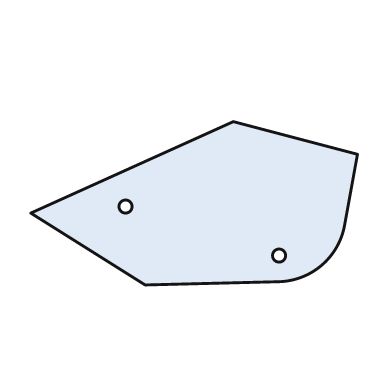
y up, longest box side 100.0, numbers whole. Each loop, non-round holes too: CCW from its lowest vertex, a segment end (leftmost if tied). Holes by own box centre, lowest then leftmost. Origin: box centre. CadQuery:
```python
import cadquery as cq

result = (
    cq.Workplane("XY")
    .moveTo(-15.0, -25.0)
    .lineTo(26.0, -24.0)
    .threePointArc((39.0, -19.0), (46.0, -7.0))
    .lineTo(50.0, 15.0)
    .lineTo(12.0, 25.0)
    .lineTo(-50.0, -3.0)
    .close()
    .moveTo(26.0, -16.0)
    .circle(2.0)
    .moveTo(-21.0, -1.0)
    .circle(2.0)
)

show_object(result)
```